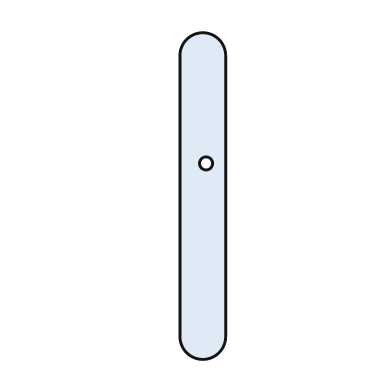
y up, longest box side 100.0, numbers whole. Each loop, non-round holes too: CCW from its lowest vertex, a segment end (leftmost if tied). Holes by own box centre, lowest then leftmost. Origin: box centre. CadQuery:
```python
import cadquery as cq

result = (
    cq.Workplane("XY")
    .moveTo(-7.0, -43.0)
    .threePointArc((0.0, -50.0), (7.0, -43.0))
    .lineTo(7.0, 43.0)
    .threePointArc((0.0, 50.0), (-7.0, 43.0))
    .close()
    .moveTo(1.0, 10.0)
    .circle(2.0)
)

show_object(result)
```